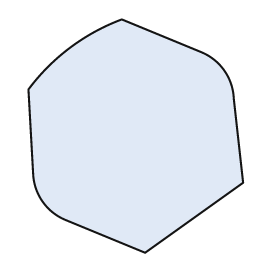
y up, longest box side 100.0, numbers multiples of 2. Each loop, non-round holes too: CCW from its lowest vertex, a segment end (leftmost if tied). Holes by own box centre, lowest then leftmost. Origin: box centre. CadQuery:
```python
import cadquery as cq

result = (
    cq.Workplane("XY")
    .moveTo(4.0, -50.0)
    .lineTo(46.0, -20.0)
    .lineTo(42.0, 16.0)
    .threePointArc((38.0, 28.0), (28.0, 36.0))
    .lineTo(-6.0, 50.0)
    .threePointArc((-28.0, 38.0), (-46.0, 20.0))
    .lineTo(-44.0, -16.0)
    .threePointArc((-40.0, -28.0), (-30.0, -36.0))
    .close()
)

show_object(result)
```